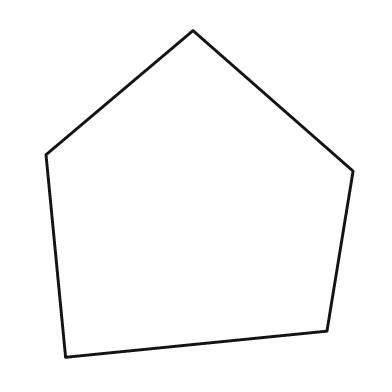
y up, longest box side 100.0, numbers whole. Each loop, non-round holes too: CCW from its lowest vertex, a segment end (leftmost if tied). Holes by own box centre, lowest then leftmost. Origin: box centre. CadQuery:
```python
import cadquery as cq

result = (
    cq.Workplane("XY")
    .moveTo(-41.0, -50.0)
    .lineTo(39.0, -42.0)
    .lineTo(47.0, 7.0)
    .lineTo(-2.0, 50.0)
    .lineTo(-47.0, 12.0)
    .close()
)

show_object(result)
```